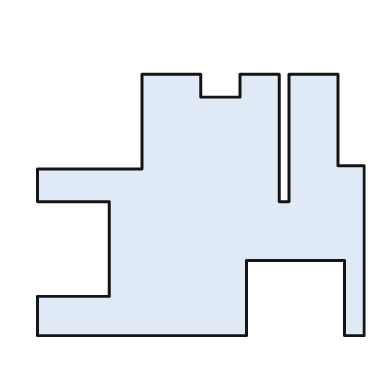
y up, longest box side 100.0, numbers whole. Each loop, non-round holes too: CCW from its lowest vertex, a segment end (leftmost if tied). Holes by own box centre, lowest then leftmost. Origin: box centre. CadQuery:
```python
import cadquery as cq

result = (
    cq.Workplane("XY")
    .moveTo(-50.0, -40.0)
    .lineTo(14.0, -40.0)
    .lineTo(14.0, -17.0)
    .lineTo(44.0, -17.0)
    .lineTo(44.0, -40.0)
    .lineTo(50.0, -40.0)
    .lineTo(50.0, 12.0)
    .lineTo(42.0, 12.0)
    .lineTo(42.0, 40.0)
    .lineTo(27.0, 40.0)
    .lineTo(27.0, 1.0)
    .lineTo(24.0, 1.0)
    .lineTo(24.0, 40.0)
    .lineTo(12.0, 40.0)
    .lineTo(12.0, 33.0)
    .lineTo(0.0, 33.0)
    .lineTo(0.0, 40.0)
    .lineTo(-18.0, 40.0)
    .lineTo(-18.0, 11.0)
    .lineTo(-50.0, 11.0)
    .lineTo(-50.0, 1.0)
    .lineTo(-28.0, 1.0)
    .lineTo(-28.0, -28.0)
    .lineTo(-50.0, -28.0)
    .close()
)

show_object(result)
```